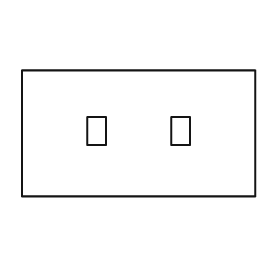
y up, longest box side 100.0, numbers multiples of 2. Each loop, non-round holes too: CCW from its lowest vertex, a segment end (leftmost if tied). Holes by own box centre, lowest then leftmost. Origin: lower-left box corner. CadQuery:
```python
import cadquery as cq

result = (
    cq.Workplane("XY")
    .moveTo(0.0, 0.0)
    .lineTo(100.0, 0.0)
    .lineTo(100.0, 54.0)
    .lineTo(0.0, 54.0)
    .close()
    .moveTo(28.0, 22.0)
    .lineTo(36.0, 22.0)
    .lineTo(36.0, 34.0)
    .lineTo(28.0, 34.0)
    .close()
    .moveTo(64.0, 22.0)
    .lineTo(72.0, 22.0)
    .lineTo(72.0, 34.0)
    .lineTo(64.0, 34.0)
    .close()
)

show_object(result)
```